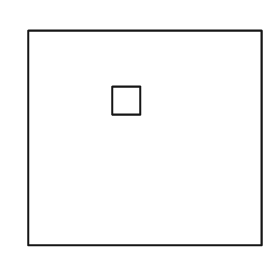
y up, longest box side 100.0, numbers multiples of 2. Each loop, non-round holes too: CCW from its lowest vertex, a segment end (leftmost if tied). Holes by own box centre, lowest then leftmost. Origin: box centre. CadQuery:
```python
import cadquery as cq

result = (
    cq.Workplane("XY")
    .moveTo(-50.0, -46.0)
    .lineTo(50.0, -46.0)
    .lineTo(50.0, 46.0)
    .lineTo(-50.0, 46.0)
    .close()
    .moveTo(-14.0, 10.0)
    .lineTo(-2.0, 10.0)
    .lineTo(-2.0, 22.0)
    .lineTo(-14.0, 22.0)
    .close()
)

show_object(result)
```